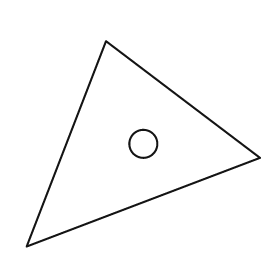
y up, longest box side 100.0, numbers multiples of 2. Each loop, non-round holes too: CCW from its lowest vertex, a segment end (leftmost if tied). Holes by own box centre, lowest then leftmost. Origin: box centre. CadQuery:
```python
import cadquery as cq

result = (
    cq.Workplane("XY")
    .moveTo(-50.0, -44.0)
    .lineTo(50.0, -6.0)
    .lineTo(-16.0, 44.0)
    .close()
    .moveTo(0.0, 0.0)
    .circle(6.0)
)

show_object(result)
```